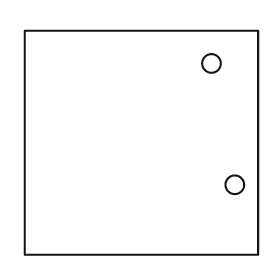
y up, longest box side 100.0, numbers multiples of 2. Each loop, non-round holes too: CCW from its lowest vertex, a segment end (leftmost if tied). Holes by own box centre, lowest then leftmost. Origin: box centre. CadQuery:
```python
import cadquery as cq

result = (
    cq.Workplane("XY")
    .moveTo(-50.0, -48.0)
    .lineTo(50.0, -48.0)
    .lineTo(50.0, 48.0)
    .lineTo(-50.0, 48.0)
    .close()
    .moveTo(40.0, -18.0)
    .circle(4.0)
    .moveTo(30.0, 34.0)
    .circle(4.0)
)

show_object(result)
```